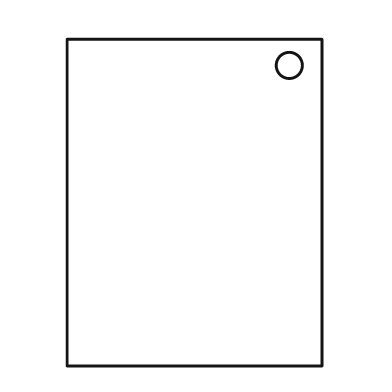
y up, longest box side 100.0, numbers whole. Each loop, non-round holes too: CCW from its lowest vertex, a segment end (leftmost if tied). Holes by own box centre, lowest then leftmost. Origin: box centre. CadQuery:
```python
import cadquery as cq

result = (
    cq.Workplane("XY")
    .moveTo(-39.0, -50.0)
    .lineTo(39.0, -50.0)
    .lineTo(39.0, 50.0)
    .lineTo(-39.0, 50.0)
    .close()
    .moveTo(29.0, 42.0)
    .circle(4.0)
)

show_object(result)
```